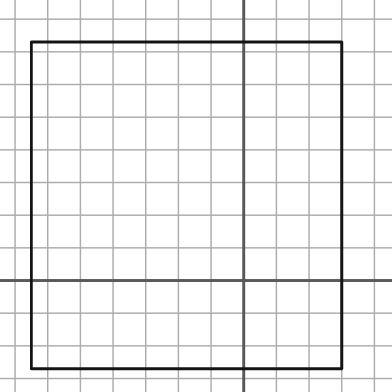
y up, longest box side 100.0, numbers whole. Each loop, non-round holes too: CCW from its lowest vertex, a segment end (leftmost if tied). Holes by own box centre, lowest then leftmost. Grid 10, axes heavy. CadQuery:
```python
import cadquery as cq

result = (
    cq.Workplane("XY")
    .moveTo(-65.0, -27.0)
    .lineTo(30.0, -27.0)
    .lineTo(30.0, 73.0)
    .lineTo(-65.0, 73.0)
    .close()
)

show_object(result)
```